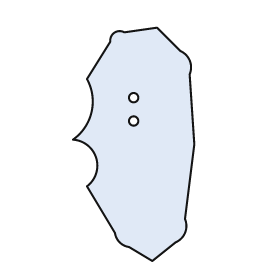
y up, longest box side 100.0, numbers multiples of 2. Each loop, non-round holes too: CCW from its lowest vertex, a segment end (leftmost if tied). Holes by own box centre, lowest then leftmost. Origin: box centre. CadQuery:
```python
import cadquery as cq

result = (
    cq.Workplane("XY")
    .moveTo(8.0, -50.0)
    .lineTo(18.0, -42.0)
    .threePointArc((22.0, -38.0), (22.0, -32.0))
    .lineTo(26.0, 0.0)
    .lineTo(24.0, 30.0)
    .threePointArc((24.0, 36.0), (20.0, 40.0))
    .lineTo(10.0, 50.0)
    .lineTo(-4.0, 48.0)
    .threePointArc((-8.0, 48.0), (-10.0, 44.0))
    .lineTo(-20.0, 28.0)
    .threePointArc((-18.0, 14.0), (-26.0, 2.0))
    .threePointArc((-16.0, -6.0), (-20.0, -18.0))
    .lineTo(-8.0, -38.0)
    .threePointArc((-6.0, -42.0), (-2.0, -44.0))
    .close()
    .moveTo(0.0, 10.0)
    .circle(2.0)
    .moveTo(0.0, 20.0)
    .circle(2.0)
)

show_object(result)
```